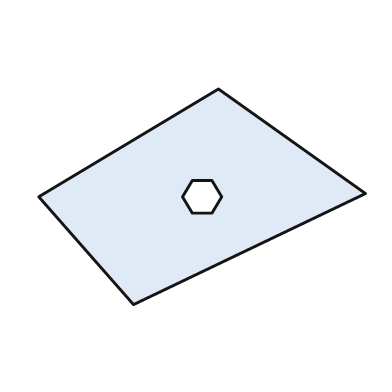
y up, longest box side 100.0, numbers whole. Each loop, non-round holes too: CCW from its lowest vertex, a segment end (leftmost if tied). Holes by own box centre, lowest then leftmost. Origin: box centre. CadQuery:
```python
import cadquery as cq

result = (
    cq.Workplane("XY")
    .moveTo(-21.0, -33.0)
    .lineTo(50.0, 1.0)
    .lineTo(5.0, 33.0)
    .lineTo(-50.0, 0.0)
    .close()
    .moveTo(-3.0, -5.0)
    .lineTo(3.0, -5.0)
    .lineTo(6.0, 0.0)
    .lineTo(3.0, 5.0)
    .lineTo(-3.0, 5.0)
    .lineTo(-6.0, 0.0)
    .close()
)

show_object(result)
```